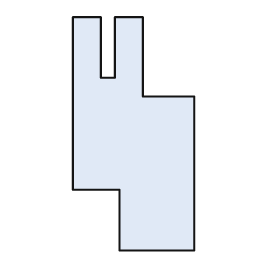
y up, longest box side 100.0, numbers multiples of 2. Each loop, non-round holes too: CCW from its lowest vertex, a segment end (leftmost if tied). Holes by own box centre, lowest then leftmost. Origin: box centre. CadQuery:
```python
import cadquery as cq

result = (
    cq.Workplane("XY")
    .moveTo(-6.0, -50.0)
    .lineTo(26.0, -50.0)
    .lineTo(26.0, 16.0)
    .lineTo(4.0, 16.0)
    .lineTo(4.0, 50.0)
    .lineTo(-8.0, 50.0)
    .lineTo(-8.0, 24.0)
    .lineTo(-14.0, 24.0)
    .lineTo(-14.0, 50.0)
    .lineTo(-26.0, 50.0)
    .lineTo(-26.0, -24.0)
    .lineTo(-6.0, -24.0)
    .close()
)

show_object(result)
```